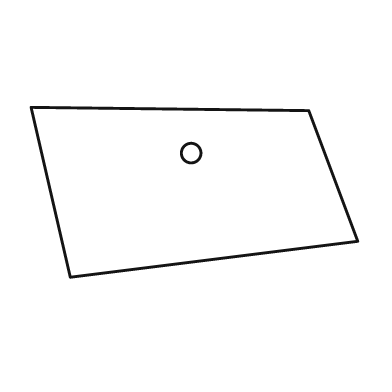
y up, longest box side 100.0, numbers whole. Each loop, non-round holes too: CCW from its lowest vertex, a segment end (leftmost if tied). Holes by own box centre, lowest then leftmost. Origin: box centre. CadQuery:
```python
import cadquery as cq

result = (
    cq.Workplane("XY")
    .moveTo(-38.0, -26.0)
    .lineTo(50.0, -15.0)
    .lineTo(35.0, 25.0)
    .lineTo(-50.0, 26.0)
    .close()
    .moveTo(-1.0, 12.0)
    .circle(3.0)
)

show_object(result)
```